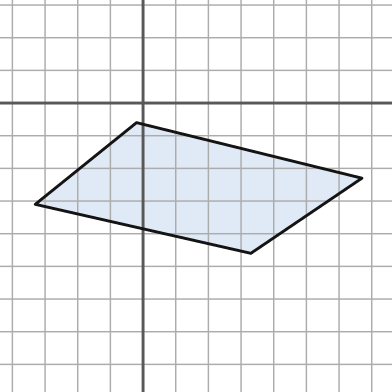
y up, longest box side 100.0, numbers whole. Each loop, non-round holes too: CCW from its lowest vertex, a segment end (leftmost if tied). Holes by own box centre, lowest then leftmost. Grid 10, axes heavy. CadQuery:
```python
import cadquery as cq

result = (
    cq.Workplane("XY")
    .moveTo(33.0, -46.0)
    .lineTo(67.0, -23.0)
    .lineTo(-2.0, -6.0)
    .lineTo(-33.0, -31.0)
    .close()
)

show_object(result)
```